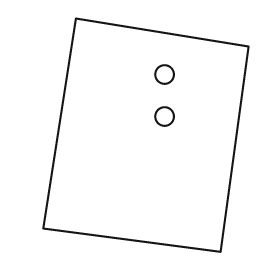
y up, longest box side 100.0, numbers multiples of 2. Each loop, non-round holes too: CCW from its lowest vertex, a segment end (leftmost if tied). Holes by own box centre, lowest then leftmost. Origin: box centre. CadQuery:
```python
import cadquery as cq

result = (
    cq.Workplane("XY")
    .moveTo(32.0, -50.0)
    .lineTo(44.0, 38.0)
    .lineTo(-30.0, 50.0)
    .lineTo(-44.0, -40.0)
    .close()
    .moveTo(8.0, 8.0)
    .circle(4.0)
    .moveTo(8.0, 26.0)
    .circle(4.0)
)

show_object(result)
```